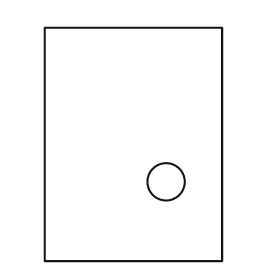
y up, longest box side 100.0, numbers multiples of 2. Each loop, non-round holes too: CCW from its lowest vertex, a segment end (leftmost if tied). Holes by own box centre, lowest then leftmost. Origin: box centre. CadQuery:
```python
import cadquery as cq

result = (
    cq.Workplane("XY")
    .moveTo(-38.0, -50.0)
    .lineTo(38.0, -50.0)
    .lineTo(38.0, 50.0)
    .lineTo(-38.0, 50.0)
    .close()
    .moveTo(14.0, -16.0)
    .circle(8.0)
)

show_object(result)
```